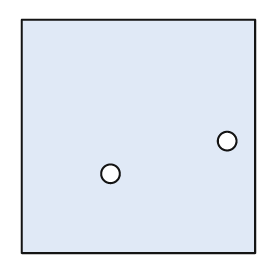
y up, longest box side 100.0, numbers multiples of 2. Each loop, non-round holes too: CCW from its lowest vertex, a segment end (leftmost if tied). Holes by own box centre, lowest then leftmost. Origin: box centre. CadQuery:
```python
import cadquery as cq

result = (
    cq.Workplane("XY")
    .moveTo(-50.0, -50.0)
    .lineTo(50.0, -50.0)
    .lineTo(50.0, 50.0)
    .lineTo(-50.0, 50.0)
    .close()
    .moveTo(-12.0, -16.0)
    .circle(4.0)
    .moveTo(38.0, -2.0)
    .circle(4.0)
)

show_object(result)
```